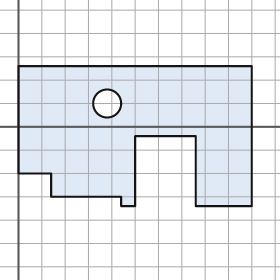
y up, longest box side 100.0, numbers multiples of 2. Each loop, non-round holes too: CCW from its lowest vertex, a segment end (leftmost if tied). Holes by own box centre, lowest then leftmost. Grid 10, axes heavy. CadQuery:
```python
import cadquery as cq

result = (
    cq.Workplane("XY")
    .moveTo(44.0, -34.0)
    .lineTo(50.0, -34.0)
    .lineTo(50.0, -4.0)
    .lineTo(76.0, -4.0)
    .lineTo(76.0, -34.0)
    .lineTo(100.0, -34.0)
    .lineTo(100.0, 26.0)
    .lineTo(0.0, 26.0)
    .lineTo(0.0, -20.0)
    .lineTo(14.0, -20.0)
    .lineTo(14.0, -30.0)
    .lineTo(44.0, -30.0)
    .close()
    .moveTo(38.0, 10.0)
    .circle(6.0)
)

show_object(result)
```